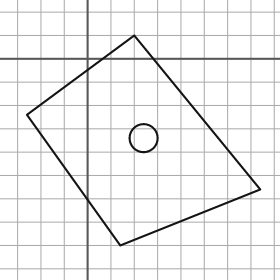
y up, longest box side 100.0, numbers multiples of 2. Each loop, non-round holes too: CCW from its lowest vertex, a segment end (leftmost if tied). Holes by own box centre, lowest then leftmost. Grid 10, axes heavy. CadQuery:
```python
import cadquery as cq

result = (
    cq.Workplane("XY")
    .moveTo(14.0, -80.0)
    .lineTo(74.0, -56.0)
    .lineTo(20.0, 10.0)
    .lineTo(-26.0, -24.0)
    .close()
    .moveTo(24.0, -34.0)
    .circle(6.0)
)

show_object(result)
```